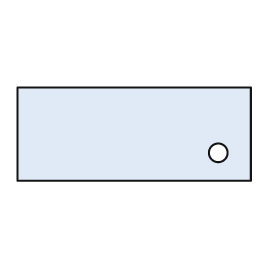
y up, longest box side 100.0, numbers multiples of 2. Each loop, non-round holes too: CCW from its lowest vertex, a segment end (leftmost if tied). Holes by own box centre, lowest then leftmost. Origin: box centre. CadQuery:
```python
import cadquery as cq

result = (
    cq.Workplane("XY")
    .moveTo(-50.0, -20.0)
    .lineTo(50.0, -20.0)
    .lineTo(50.0, 20.0)
    .lineTo(-50.0, 20.0)
    .close()
    .moveTo(36.0, -8.0)
    .circle(4.0)
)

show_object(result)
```